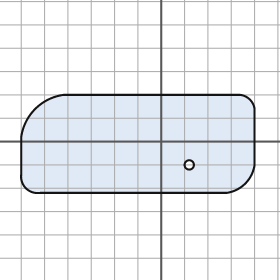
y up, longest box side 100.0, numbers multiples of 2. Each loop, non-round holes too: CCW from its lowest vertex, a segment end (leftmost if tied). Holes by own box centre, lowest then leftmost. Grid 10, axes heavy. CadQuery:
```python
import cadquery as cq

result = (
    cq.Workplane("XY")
    .moveTo(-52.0, -22.0)
    .lineTo(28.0, -22.0)
    .threePointArc((36.0, -18.0), (40.0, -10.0))
    .lineTo(40.0, 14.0)
    .threePointArc((38.0, 18.0), (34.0, 20.0))
    .lineTo(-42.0, 20.0)
    .threePointArc((-54.0, 14.0), (-60.0, 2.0))
    .lineTo(-60.0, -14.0)
    .threePointArc((-58.0, -20.0), (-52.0, -22.0))
    .close()
    .moveTo(12.0, -10.0)
    .circle(2.0)
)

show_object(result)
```